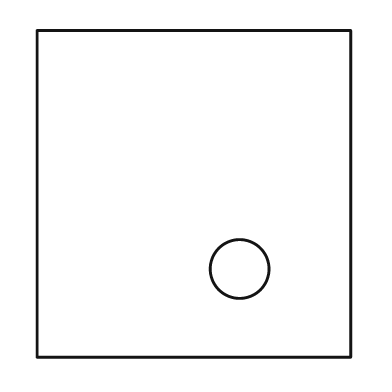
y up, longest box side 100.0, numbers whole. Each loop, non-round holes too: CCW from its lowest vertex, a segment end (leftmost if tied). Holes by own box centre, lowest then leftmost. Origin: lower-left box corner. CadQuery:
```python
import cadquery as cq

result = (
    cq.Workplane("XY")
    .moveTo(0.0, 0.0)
    .lineTo(96.0, 0.0)
    .lineTo(96.0, 100.0)
    .lineTo(0.0, 100.0)
    .close()
    .moveTo(62.0, 27.0)
    .circle(9.0)
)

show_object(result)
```